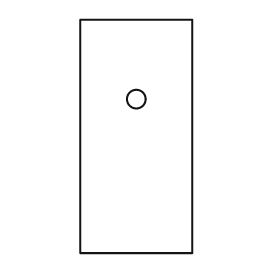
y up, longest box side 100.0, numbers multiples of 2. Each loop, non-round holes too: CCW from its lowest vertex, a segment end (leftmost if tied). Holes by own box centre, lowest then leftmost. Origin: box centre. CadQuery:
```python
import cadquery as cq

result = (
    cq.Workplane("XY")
    .moveTo(-24.0, -50.0)
    .lineTo(24.0, -50.0)
    .lineTo(24.0, 50.0)
    .lineTo(-24.0, 50.0)
    .close()
    .moveTo(0.0, 16.0)
    .circle(4.0)
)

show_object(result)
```